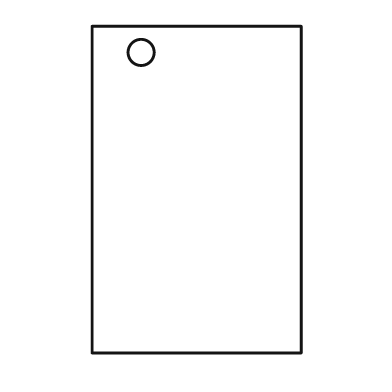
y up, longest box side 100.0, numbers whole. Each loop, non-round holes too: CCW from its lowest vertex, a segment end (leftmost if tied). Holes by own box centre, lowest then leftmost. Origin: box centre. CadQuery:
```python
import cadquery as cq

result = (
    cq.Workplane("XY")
    .moveTo(-32.0, -50.0)
    .lineTo(32.0, -50.0)
    .lineTo(32.0, 50.0)
    .lineTo(-32.0, 50.0)
    .close()
    .moveTo(-17.0, 42.0)
    .circle(4.0)
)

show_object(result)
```